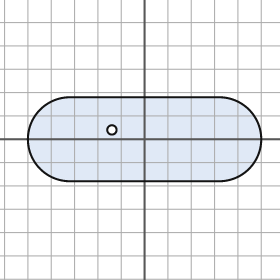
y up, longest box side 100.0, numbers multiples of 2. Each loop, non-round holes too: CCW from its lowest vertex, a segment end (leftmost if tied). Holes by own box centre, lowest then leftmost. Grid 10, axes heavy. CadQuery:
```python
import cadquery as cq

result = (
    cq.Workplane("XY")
    .moveTo(-32.0, -18.0)
    .lineTo(32.0, -18.0)
    .threePointArc((50.0, 0.0), (32.0, 18.0))
    .lineTo(-32.0, 18.0)
    .threePointArc((-50.0, 0.0), (-32.0, -18.0))
    .close()
    .moveTo(-14.0, 4.0)
    .circle(2.0)
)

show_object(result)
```